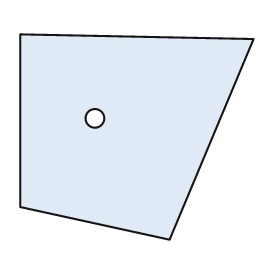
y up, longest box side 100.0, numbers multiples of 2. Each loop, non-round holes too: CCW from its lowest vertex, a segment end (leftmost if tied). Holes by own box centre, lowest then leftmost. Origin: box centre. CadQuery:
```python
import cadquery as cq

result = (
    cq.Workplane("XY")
    .moveTo(14.0, -44.0)
    .lineTo(50.0, 42.0)
    .lineTo(-50.0, 44.0)
    .lineTo(-50.0, -30.0)
    .close()
    .moveTo(-18.0, 8.0)
    .circle(4.0)
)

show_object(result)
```